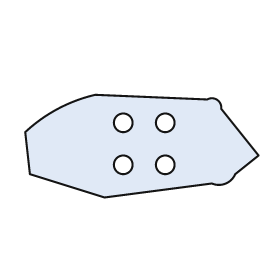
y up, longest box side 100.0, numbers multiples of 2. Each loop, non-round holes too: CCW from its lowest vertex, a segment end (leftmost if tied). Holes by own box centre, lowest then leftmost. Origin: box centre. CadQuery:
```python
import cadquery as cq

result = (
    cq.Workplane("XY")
    .moveTo(-16.0, -22.0)
    .lineTo(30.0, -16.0)
    .threePointArc((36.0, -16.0), (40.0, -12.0))
    .lineTo(50.0, -4.0)
    .lineTo(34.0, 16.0)
    .threePointArc((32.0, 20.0), (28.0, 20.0))
    .lineTo(-20.0, 22.0)
    .threePointArc((-36.0, 16.0), (-50.0, 6.0))
    .lineTo(-48.0, -12.0)
    .close()
    .moveTo(-8.0, -8.0)
    .circle(4.0)
    .moveTo(10.0, -8.0)
    .circle(4.0)
    .moveTo(-8.0, 10.0)
    .circle(4.0)
    .moveTo(10.0, 10.0)
    .circle(4.0)
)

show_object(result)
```